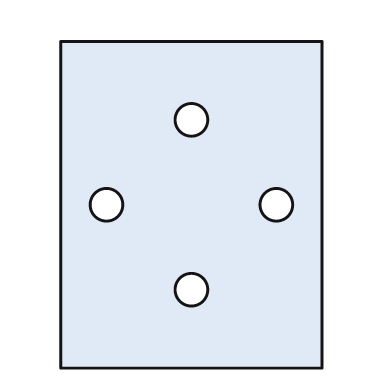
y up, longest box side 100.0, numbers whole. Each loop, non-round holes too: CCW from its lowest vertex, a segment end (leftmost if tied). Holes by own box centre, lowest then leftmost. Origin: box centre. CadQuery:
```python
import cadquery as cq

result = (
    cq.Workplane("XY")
    .moveTo(-40.0, -50.0)
    .lineTo(40.0, -50.0)
    .lineTo(40.0, 50.0)
    .lineTo(-40.0, 50.0)
    .close()
    .moveTo(0.0, -26.0)
    .circle(5.0)
    .moveTo(-26.0, 0.0)
    .circle(5.0)
    .moveTo(26.0, 0.0)
    .circle(5.0)
    .moveTo(0.0, 26.0)
    .circle(5.0)
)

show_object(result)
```